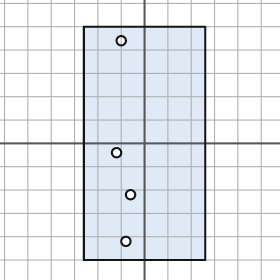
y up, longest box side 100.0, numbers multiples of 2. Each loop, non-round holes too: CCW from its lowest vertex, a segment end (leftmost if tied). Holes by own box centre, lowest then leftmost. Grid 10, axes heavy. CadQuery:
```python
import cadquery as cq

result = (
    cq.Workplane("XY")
    .moveTo(-26.0, -50.0)
    .lineTo(26.0, -50.0)
    .lineTo(26.0, 50.0)
    .lineTo(-26.0, 50.0)
    .close()
    .moveTo(-8.0, -42.0)
    .circle(2.0)
    .moveTo(-6.0, -22.0)
    .circle(2.0)
    .moveTo(-12.0, -4.0)
    .circle(2.0)
    .moveTo(-10.0, 44.0)
    .circle(2.0)
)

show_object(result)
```